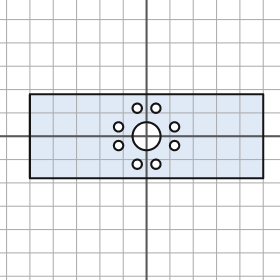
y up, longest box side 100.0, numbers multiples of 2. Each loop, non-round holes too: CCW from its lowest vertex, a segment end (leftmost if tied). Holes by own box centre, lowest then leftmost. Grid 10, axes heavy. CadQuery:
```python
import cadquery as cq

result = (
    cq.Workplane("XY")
    .moveTo(-50.0, -18.0)
    .lineTo(50.0, -18.0)
    .lineTo(50.0, 18.0)
    .lineTo(-50.0, 18.0)
    .close()
    .moveTo(-4.0, -12.0)
    .circle(2.0)
    .moveTo(4.0, -12.0)
    .circle(2.0)
    .moveTo(-12.0, -4.0)
    .circle(2.0)
    .moveTo(12.0, -4.0)
    .circle(2.0)
    .moveTo(0.0, 0.0)
    .circle(6.0)
    .moveTo(-12.0, 4.0)
    .circle(2.0)
    .moveTo(12.0, 4.0)
    .circle(2.0)
    .moveTo(-4.0, 12.0)
    .circle(2.0)
    .moveTo(4.0, 12.0)
    .circle(2.0)
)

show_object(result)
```